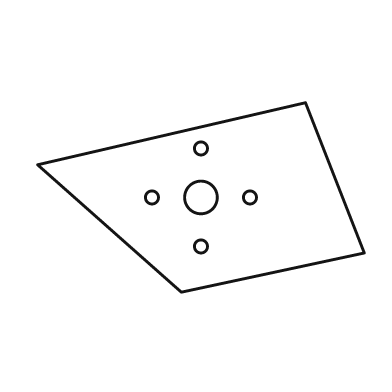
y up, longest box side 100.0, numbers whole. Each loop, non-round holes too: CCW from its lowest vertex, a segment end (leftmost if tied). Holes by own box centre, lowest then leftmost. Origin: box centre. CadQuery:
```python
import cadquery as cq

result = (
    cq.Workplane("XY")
    .moveTo(-6.0, -29.0)
    .lineTo(50.0, -17.0)
    .lineTo(32.0, 29.0)
    .lineTo(-50.0, 10.0)
    .close()
    .moveTo(0.0, -15.0)
    .circle(2.0)
    .moveTo(-15.0, 0.0)
    .circle(2.0)
    .moveTo(0.0, 0.0)
    .circle(5.0)
    .moveTo(15.0, 0.0)
    .circle(2.0)
    .moveTo(0.0, 15.0)
    .circle(2.0)
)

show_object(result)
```